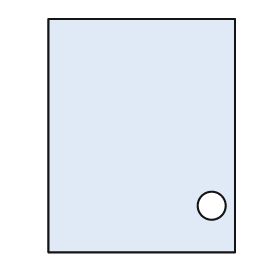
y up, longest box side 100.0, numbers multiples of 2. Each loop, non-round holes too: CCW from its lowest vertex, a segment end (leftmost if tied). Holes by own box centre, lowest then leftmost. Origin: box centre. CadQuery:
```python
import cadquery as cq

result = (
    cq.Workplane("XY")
    .moveTo(-40.0, -50.0)
    .lineTo(40.0, -50.0)
    .lineTo(40.0, 50.0)
    .lineTo(-40.0, 50.0)
    .close()
    .moveTo(30.0, -30.0)
    .circle(6.0)
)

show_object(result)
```